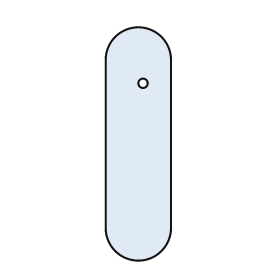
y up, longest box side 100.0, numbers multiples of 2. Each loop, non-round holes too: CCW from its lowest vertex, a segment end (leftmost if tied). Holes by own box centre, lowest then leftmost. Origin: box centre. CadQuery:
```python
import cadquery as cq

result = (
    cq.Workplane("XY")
    .moveTo(-14.0, -36.0)
    .threePointArc((0.0, -50.0), (14.0, -36.0))
    .lineTo(14.0, 36.0)
    .threePointArc((0.0, 50.0), (-14.0, 36.0))
    .close()
    .moveTo(2.0, 26.0)
    .circle(2.0)
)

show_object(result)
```